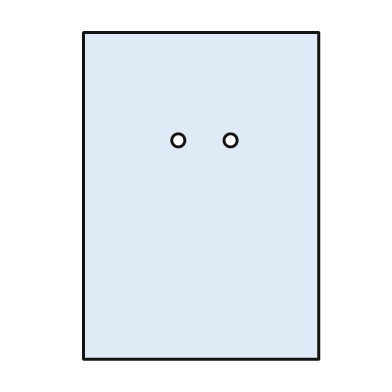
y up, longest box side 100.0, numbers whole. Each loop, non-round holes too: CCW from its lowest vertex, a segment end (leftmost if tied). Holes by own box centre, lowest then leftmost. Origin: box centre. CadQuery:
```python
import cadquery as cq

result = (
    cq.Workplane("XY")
    .moveTo(-36.0, -50.0)
    .lineTo(36.0, -50.0)
    .lineTo(36.0, 50.0)
    .lineTo(-36.0, 50.0)
    .close()
    .moveTo(-7.0, 17.0)
    .circle(2.0)
    .moveTo(9.0, 17.0)
    .circle(2.0)
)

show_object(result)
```